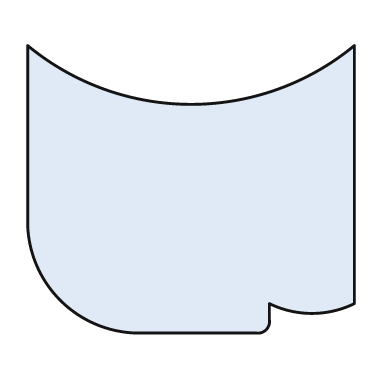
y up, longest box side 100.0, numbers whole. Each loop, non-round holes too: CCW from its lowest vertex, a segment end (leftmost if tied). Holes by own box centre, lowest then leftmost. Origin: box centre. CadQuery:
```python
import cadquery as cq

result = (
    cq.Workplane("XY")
    .moveTo(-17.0, -44.0)
    .lineTo(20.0, -44.0)
    .threePointArc((23.0, -43.0), (24.0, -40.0))
    .lineTo(24.0, -35.0)
    .threePointArc((37.0, -38.0), (50.0, -35.0))
    .lineTo(50.0, 44.0)
    .threePointArc((0.0, 26.0), (-50.0, 44.0))
    .lineTo(-50.0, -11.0)
    .threePointArc((-40.0, -34.0), (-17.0, -44.0))
    .close()
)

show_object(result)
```